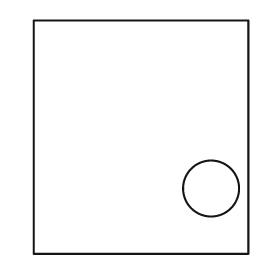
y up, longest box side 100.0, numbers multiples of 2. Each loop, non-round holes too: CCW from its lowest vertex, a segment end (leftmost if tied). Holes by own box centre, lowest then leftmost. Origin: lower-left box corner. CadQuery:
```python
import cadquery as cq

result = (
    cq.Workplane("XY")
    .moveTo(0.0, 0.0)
    .lineTo(92.0, 0.0)
    .lineTo(92.0, 100.0)
    .lineTo(0.0, 100.0)
    .close()
    .moveTo(76.0, 28.0)
    .circle(12.0)
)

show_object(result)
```